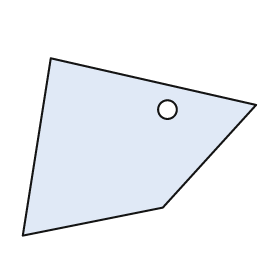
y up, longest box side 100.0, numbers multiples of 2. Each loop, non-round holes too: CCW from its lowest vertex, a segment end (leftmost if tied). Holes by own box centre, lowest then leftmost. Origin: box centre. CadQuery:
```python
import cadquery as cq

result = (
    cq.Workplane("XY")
    .moveTo(-50.0, -38.0)
    .lineTo(10.0, -26.0)
    .lineTo(50.0, 18.0)
    .lineTo(-38.0, 38.0)
    .close()
    .moveTo(12.0, 16.0)
    .circle(4.0)
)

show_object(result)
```